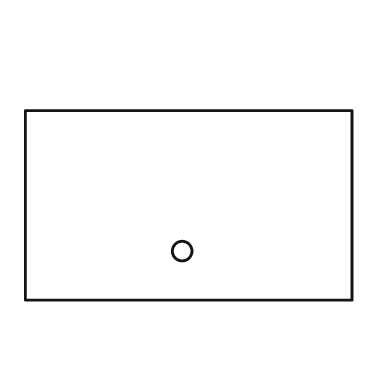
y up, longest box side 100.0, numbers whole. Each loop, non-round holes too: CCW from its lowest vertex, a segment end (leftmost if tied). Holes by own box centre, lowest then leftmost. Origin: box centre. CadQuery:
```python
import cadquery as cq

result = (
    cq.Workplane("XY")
    .moveTo(-50.0, -29.0)
    .lineTo(50.0, -29.0)
    .lineTo(50.0, 29.0)
    .lineTo(-50.0, 29.0)
    .close()
    .moveTo(-2.0, -14.0)
    .circle(3.0)
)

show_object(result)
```